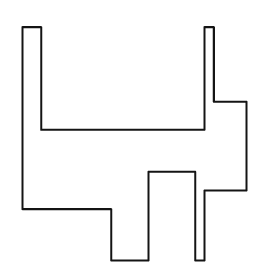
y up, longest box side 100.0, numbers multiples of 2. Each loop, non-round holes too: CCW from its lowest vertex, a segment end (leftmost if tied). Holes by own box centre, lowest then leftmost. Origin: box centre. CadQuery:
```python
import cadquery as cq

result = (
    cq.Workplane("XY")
    .moveTo(-10.0, -50.0)
    .lineTo(6.0, -50.0)
    .lineTo(6.0, -12.0)
    .lineTo(26.0, -12.0)
    .lineTo(26.0, -50.0)
    .lineTo(30.0, -50.0)
    .lineTo(30.0, -20.0)
    .lineTo(48.0, -20.0)
    .lineTo(48.0, 18.0)
    .lineTo(34.0, 18.0)
    .lineTo(34.0, 50.0)
    .lineTo(30.0, 50.0)
    .lineTo(30.0, 6.0)
    .lineTo(-40.0, 6.0)
    .lineTo(-40.0, 50.0)
    .lineTo(-48.0, 50.0)
    .lineTo(-48.0, -28.0)
    .lineTo(-10.0, -28.0)
    .close()
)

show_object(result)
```